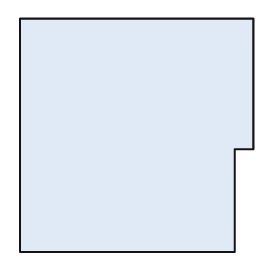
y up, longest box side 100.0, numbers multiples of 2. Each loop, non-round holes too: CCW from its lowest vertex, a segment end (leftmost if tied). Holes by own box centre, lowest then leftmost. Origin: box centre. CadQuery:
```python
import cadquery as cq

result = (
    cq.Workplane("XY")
    .moveTo(-50.0, -50.0)
    .lineTo(42.0, -50.0)
    .lineTo(42.0, -6.0)
    .lineTo(50.0, -6.0)
    .lineTo(50.0, 50.0)
    .lineTo(-50.0, 50.0)
    .close()
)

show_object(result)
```